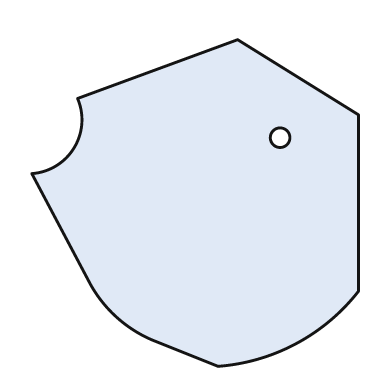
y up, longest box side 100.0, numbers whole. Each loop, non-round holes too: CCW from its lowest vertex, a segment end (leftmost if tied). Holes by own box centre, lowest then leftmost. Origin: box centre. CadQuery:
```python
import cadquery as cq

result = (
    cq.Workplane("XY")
    .moveTo(7.0, -50.0)
    .threePointArc((31.0, -43.0), (50.0, -27.0))
    .lineTo(50.0, 27.0)
    .lineTo(13.0, 50.0)
    .lineTo(-36.0, 32.0)
    .threePointArc((-37.0, 17.0), (-50.0, 9.0))
    .lineTo(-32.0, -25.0)
    .threePointArc((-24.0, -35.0), (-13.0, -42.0))
    .close()
    .moveTo(26.0, 20.0)
    .circle(3.0)
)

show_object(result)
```